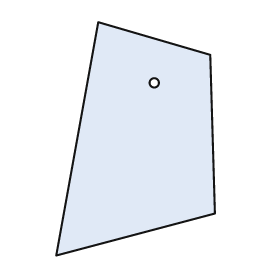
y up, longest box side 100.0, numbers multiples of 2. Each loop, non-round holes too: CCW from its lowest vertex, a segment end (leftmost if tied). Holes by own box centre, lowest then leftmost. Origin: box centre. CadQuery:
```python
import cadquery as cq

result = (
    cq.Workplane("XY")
    .moveTo(-34.0, -50.0)
    .lineTo(34.0, -32.0)
    .lineTo(32.0, 36.0)
    .lineTo(-16.0, 50.0)
    .close()
    .moveTo(8.0, 24.0)
    .circle(2.0)
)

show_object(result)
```